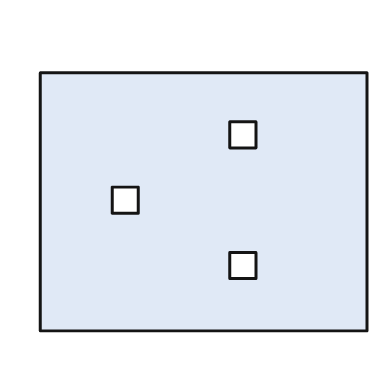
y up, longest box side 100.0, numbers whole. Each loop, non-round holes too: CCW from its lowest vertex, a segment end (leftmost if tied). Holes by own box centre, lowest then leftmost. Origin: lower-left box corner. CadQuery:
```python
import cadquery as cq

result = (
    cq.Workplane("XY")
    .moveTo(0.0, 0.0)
    .lineTo(100.0, 0.0)
    .lineTo(100.0, 79.0)
    .lineTo(0.0, 79.0)
    .close()
    .moveTo(58.0, 16.0)
    .lineTo(66.0, 16.0)
    .lineTo(66.0, 24.0)
    .lineTo(58.0, 24.0)
    .close()
    .moveTo(22.0, 36.0)
    .lineTo(30.0, 36.0)
    .lineTo(30.0, 44.0)
    .lineTo(22.0, 44.0)
    .close()
    .moveTo(58.0, 56.0)
    .lineTo(66.0, 56.0)
    .lineTo(66.0, 64.0)
    .lineTo(58.0, 64.0)
    .close()
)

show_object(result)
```